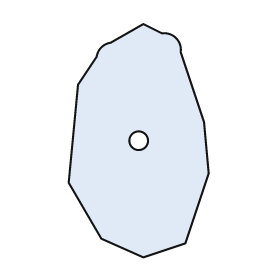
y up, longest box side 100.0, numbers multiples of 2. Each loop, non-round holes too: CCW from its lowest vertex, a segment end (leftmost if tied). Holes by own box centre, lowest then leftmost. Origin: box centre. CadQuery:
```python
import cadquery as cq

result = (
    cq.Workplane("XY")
    .moveTo(2.0, -50.0)
    .lineTo(20.0, -44.0)
    .lineTo(30.0, -14.0)
    .lineTo(28.0, 8.0)
    .lineTo(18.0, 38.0)
    .threePointArc((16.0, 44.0), (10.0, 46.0))
    .lineTo(2.0, 50.0)
    .lineTo(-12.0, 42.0)
    .threePointArc((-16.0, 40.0), (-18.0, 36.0))
    .lineTo(-26.0, 24.0)
    .lineTo(-30.0, -18.0)
    .lineTo(-16.0, -42.0)
    .close()
    .moveTo(0.0, 0.0)
    .circle(4.0)
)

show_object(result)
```